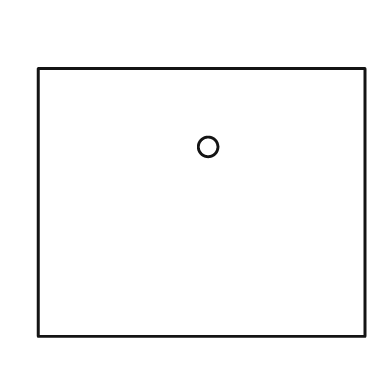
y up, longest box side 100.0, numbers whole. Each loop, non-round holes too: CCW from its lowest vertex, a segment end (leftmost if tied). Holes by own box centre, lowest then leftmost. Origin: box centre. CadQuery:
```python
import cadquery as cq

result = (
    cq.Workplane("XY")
    .moveTo(-50.0, -41.0)
    .lineTo(50.0, -41.0)
    .lineTo(50.0, 41.0)
    .lineTo(-50.0, 41.0)
    .close()
    .moveTo(2.0, 17.0)
    .circle(3.0)
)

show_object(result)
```